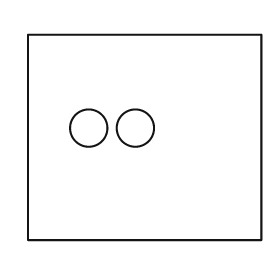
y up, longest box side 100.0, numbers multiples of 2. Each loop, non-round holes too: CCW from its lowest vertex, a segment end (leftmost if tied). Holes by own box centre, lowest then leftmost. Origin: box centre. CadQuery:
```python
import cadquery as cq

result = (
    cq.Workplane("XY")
    .moveTo(-50.0, -44.0)
    .lineTo(50.0, -44.0)
    .lineTo(50.0, 44.0)
    .lineTo(-50.0, 44.0)
    .close()
    .moveTo(-24.0, 4.0)
    .circle(8.0)
    .moveTo(-4.0, 4.0)
    .circle(8.0)
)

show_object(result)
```